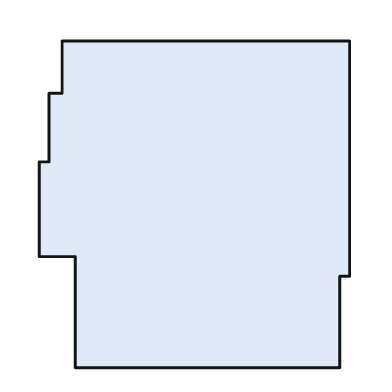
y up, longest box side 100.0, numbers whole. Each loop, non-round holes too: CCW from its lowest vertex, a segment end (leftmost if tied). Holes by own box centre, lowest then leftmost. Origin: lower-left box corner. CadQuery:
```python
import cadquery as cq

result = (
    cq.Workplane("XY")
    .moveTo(11.0, 0.0)
    .lineTo(92.0, 0.0)
    .lineTo(92.0, 28.0)
    .lineTo(95.0, 28.0)
    .lineTo(95.0, 100.0)
    .lineTo(7.0, 100.0)
    .lineTo(7.0, 84.0)
    .lineTo(3.0, 84.0)
    .lineTo(3.0, 63.0)
    .lineTo(0.0, 63.0)
    .lineTo(0.0, 34.0)
    .lineTo(11.0, 34.0)
    .close()
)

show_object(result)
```